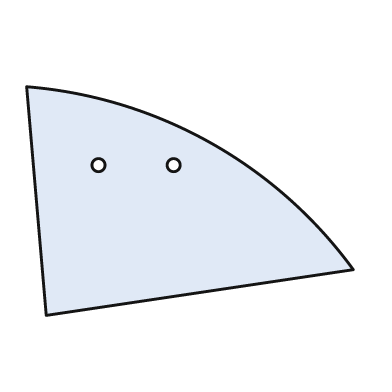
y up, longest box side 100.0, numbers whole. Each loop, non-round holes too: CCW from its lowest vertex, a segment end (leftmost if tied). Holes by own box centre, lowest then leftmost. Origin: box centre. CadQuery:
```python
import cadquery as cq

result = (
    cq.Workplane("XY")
    .moveTo(-44.0, -35.0)
    .lineTo(50.0, -21.0)
    .threePointArc((6.0, 18.0), (-50.0, 35.0))
    .close()
    .moveTo(-28.0, 11.0)
    .circle(2.0)
    .moveTo(-5.0, 11.0)
    .circle(2.0)
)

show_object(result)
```